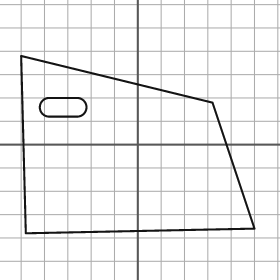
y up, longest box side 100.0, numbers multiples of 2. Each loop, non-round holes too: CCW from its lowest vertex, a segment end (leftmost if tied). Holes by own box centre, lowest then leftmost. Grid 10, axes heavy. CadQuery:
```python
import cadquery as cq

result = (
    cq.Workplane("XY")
    .moveTo(-48.0, -38.0)
    .lineTo(50.0, -36.0)
    .lineTo(32.0, 18.0)
    .lineTo(-50.0, 38.0)
    .close()
    .moveTo(-38.0, 12.0)
    .lineTo(-26.0, 12.0)
    .threePointArc((-22.0, 16.0), (-26.0, 20.0))
    .lineTo(-38.0, 20.0)
    .threePointArc((-42.0, 16.0), (-38.0, 12.0))
    .close()
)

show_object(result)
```